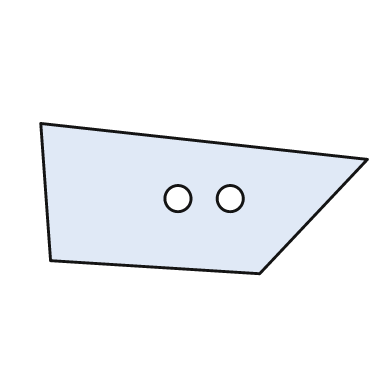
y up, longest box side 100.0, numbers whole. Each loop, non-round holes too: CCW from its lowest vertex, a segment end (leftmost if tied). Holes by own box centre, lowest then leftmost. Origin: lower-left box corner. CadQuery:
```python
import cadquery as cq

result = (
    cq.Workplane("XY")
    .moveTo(67.0, 0.0)
    .lineTo(100.0, 35.0)
    .lineTo(0.0, 46.0)
    .lineTo(3.0, 4.0)
    .close()
    .moveTo(42.0, 23.0)
    .circle(4.0)
    .moveTo(58.0, 23.0)
    .circle(4.0)
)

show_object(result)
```